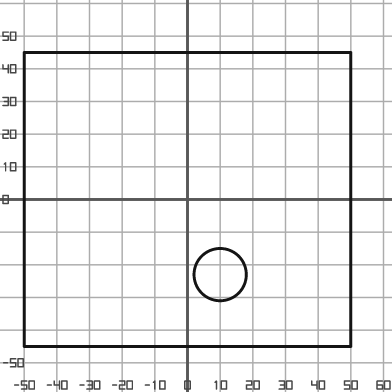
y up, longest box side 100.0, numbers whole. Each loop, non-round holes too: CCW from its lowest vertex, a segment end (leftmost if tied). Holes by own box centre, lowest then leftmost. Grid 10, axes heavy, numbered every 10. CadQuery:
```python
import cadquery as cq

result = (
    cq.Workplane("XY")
    .moveTo(-50.0, -45.0)
    .lineTo(50.0, -45.0)
    .lineTo(50.0, 45.0)
    .lineTo(-50.0, 45.0)
    .close()
    .moveTo(10.0, -23.0)
    .circle(8.0)
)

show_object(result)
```